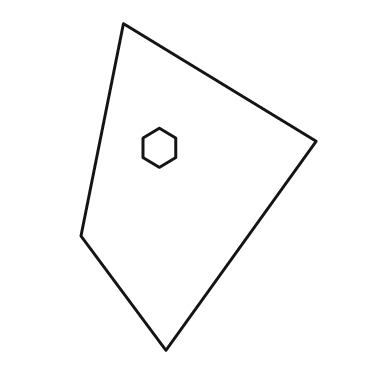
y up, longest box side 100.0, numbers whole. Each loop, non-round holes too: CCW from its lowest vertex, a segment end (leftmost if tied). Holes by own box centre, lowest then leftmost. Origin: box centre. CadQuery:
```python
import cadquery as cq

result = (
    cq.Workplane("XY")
    .moveTo(-10.0, -50.0)
    .lineTo(36.0, 14.0)
    .lineTo(-23.0, 50.0)
    .lineTo(-36.0, -15.0)
    .close()
    .moveTo(-12.0, 6.0)
    .lineTo(-7.0, 9.0)
    .lineTo(-7.0, 15.0)
    .lineTo(-12.0, 18.0)
    .lineTo(-17.0, 15.0)
    .lineTo(-17.0, 9.0)
    .close()
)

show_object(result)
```